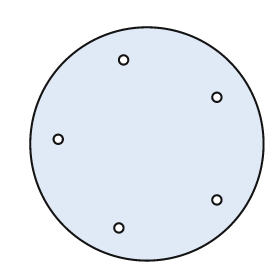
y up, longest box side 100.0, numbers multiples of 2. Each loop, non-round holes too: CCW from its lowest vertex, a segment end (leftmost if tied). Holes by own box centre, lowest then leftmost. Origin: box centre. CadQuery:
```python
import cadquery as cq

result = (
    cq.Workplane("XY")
    .moveTo(0.0, 0.0)
    .circle(50.0)
    .moveTo(-12.0, -36.0)
    .circle(2.0)
    .moveTo(30.0, -24.0)
    .circle(2.0)
    .moveTo(-38.0, 2.0)
    .circle(2.0)
    .moveTo(30.0, 20.0)
    .circle(2.0)
    .moveTo(-10.0, 36.0)
    .circle(2.0)
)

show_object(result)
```